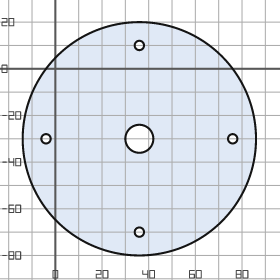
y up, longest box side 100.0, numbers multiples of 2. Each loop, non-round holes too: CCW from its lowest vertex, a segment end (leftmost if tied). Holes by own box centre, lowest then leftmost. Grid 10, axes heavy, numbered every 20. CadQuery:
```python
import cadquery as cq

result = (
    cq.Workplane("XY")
    .moveTo(36.0, -30.0)
    .circle(50.0)
    .moveTo(36.0, -70.0)
    .circle(2.0)
    .moveTo(-4.0, -30.0)
    .circle(2.0)
    .moveTo(36.0, -30.0)
    .circle(6.0)
    .moveTo(76.0, -30.0)
    .circle(2.0)
    .moveTo(36.0, 10.0)
    .circle(2.0)
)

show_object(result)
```